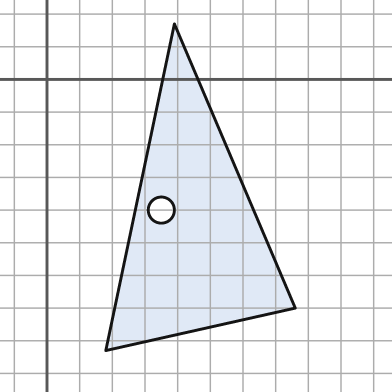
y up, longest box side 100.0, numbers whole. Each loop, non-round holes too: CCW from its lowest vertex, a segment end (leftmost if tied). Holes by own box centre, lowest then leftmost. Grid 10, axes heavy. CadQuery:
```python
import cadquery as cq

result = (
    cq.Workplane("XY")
    .moveTo(18.0, -83.0)
    .lineTo(76.0, -70.0)
    .lineTo(39.0, 17.0)
    .close()
    .moveTo(35.0, -40.0)
    .circle(4.0)
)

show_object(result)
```